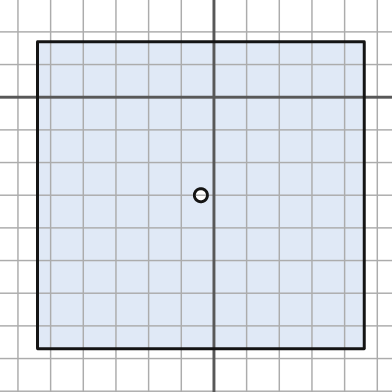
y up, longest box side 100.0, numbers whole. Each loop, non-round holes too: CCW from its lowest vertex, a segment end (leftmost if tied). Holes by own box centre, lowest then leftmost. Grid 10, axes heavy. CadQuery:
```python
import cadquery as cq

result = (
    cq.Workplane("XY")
    .moveTo(-54.0, -77.0)
    .lineTo(46.0, -77.0)
    .lineTo(46.0, 17.0)
    .lineTo(-54.0, 17.0)
    .close()
    .moveTo(-4.0, -30.0)
    .circle(2.0)
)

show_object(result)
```